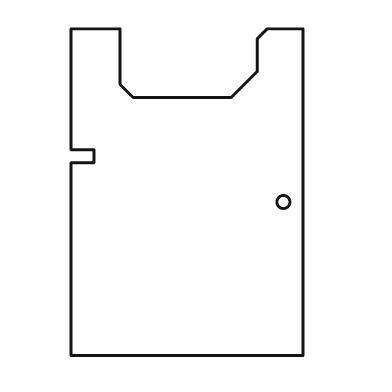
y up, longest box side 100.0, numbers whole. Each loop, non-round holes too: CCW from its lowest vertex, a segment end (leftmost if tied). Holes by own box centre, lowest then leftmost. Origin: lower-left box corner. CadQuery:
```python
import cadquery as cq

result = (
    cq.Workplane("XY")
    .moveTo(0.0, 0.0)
    .lineTo(71.0, 0.0)
    .lineTo(71.0, 100.0)
    .lineTo(60.0, 100.0)
    .lineTo(57.0, 97.0)
    .lineTo(57.0, 87.0)
    .lineTo(49.0, 79.0)
    .lineTo(19.0, 79.0)
    .lineTo(15.0, 83.0)
    .lineTo(15.0, 100.0)
    .lineTo(0.0, 100.0)
    .lineTo(0.0, 63.0)
    .lineTo(7.0, 63.0)
    .lineTo(7.0, 59.0)
    .lineTo(0.0, 59.0)
    .close()
    .moveTo(65.0, 47.0)
    .circle(2.0)
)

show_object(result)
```